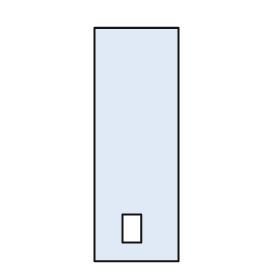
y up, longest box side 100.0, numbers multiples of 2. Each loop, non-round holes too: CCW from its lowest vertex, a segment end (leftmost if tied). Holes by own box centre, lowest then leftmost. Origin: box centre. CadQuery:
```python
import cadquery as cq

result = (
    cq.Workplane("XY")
    .moveTo(-18.0, -50.0)
    .lineTo(18.0, -50.0)
    .lineTo(18.0, 50.0)
    .lineTo(-18.0, 50.0)
    .close()
    .moveTo(-6.0, -42.0)
    .lineTo(2.0, -42.0)
    .lineTo(2.0, -30.0)
    .lineTo(-6.0, -30.0)
    .close()
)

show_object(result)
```